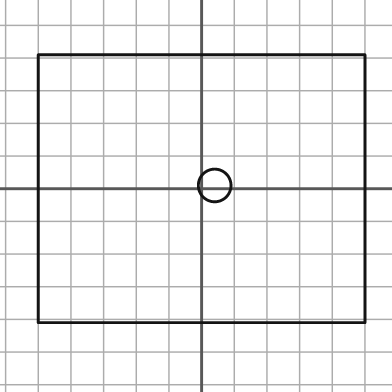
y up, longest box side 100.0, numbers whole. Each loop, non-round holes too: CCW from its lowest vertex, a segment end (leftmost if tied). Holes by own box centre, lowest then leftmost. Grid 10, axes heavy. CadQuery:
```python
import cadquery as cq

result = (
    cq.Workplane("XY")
    .moveTo(-50.0, -41.0)
    .lineTo(50.0, -41.0)
    .lineTo(50.0, 41.0)
    .lineTo(-50.0, 41.0)
    .close()
    .moveTo(4.0, 1.0)
    .circle(5.0)
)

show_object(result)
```